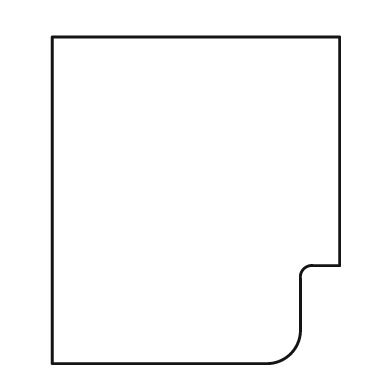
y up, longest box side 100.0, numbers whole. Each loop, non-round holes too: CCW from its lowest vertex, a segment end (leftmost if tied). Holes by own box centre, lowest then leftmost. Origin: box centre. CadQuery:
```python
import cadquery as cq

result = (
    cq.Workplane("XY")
    .moveTo(-44.0, -50.0)
    .lineTo(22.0, -50.0)
    .threePointArc((29.0, -47.0), (32.0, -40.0))
    .lineTo(32.0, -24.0)
    .threePointArc((33.0, -21.0), (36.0, -20.0))
    .lineTo(44.0, -20.0)
    .lineTo(44.0, 50.0)
    .lineTo(-44.0, 50.0)
    .close()
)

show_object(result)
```